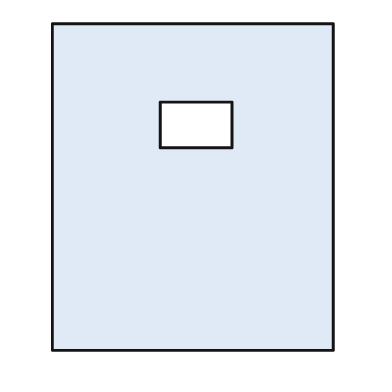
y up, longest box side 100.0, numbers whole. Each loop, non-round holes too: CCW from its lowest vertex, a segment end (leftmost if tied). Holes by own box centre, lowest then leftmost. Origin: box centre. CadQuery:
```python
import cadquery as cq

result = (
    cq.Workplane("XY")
    .moveTo(-43.0, -50.0)
    .lineTo(43.0, -50.0)
    .lineTo(43.0, 50.0)
    .lineTo(-43.0, 50.0)
    .close()
    .moveTo(-10.0, 12.0)
    .lineTo(12.0, 12.0)
    .lineTo(12.0, 26.0)
    .lineTo(-10.0, 26.0)
    .close()
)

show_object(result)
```